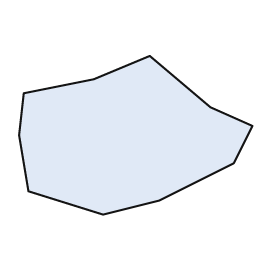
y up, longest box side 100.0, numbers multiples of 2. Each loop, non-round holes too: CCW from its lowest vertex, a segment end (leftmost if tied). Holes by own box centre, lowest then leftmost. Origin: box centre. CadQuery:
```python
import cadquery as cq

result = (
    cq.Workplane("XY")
    .moveTo(-14.0, -34.0)
    .lineTo(10.0, -28.0)
    .lineTo(42.0, -12.0)
    .lineTo(50.0, 4.0)
    .lineTo(32.0, 12.0)
    .lineTo(6.0, 34.0)
    .lineTo(-18.0, 24.0)
    .lineTo(-48.0, 18.0)
    .lineTo(-50.0, 0.0)
    .lineTo(-46.0, -24.0)
    .close()
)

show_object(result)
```